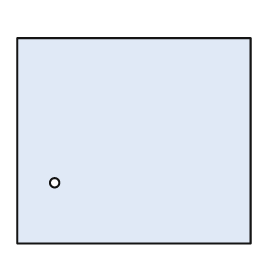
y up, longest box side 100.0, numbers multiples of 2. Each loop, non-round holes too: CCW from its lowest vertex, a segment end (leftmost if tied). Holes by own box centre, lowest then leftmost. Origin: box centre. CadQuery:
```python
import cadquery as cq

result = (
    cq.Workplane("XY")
    .moveTo(-50.0, -44.0)
    .lineTo(50.0, -44.0)
    .lineTo(50.0, 44.0)
    .lineTo(-50.0, 44.0)
    .close()
    .moveTo(-34.0, -18.0)
    .circle(2.0)
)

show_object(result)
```